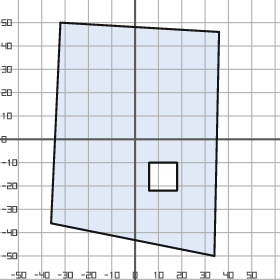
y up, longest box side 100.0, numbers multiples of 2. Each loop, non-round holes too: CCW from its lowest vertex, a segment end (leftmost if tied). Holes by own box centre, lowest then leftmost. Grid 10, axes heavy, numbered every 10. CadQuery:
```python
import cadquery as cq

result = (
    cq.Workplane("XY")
    .moveTo(34.0, -50.0)
    .lineTo(36.0, 46.0)
    .lineTo(-32.0, 50.0)
    .lineTo(-36.0, -36.0)
    .close()
    .moveTo(6.0, -22.0)
    .lineTo(18.0, -22.0)
    .lineTo(18.0, -10.0)
    .lineTo(6.0, -10.0)
    .close()
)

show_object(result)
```